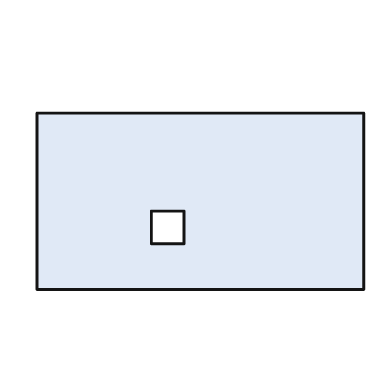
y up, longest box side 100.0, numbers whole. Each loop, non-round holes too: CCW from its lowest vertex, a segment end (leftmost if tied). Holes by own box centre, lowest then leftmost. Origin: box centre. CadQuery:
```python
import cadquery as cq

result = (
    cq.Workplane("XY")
    .moveTo(-50.0, -27.0)
    .lineTo(50.0, -27.0)
    .lineTo(50.0, 27.0)
    .lineTo(-50.0, 27.0)
    .close()
    .moveTo(-15.0, -13.0)
    .lineTo(-5.0, -13.0)
    .lineTo(-5.0, -3.0)
    .lineTo(-15.0, -3.0)
    .close()
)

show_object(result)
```